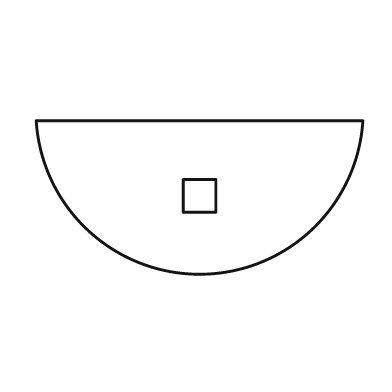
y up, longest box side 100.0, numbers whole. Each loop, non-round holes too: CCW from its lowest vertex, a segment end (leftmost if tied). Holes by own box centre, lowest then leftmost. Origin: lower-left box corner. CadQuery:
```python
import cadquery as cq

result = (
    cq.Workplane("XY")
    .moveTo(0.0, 47.0)
    .threePointArc((50.0, 0.0), (100.0, 47.0))
    .close()
    .moveTo(45.0, 19.0)
    .lineTo(55.0, 19.0)
    .lineTo(55.0, 29.0)
    .lineTo(45.0, 29.0)
    .close()
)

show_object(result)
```